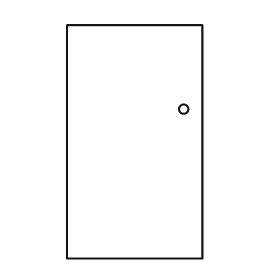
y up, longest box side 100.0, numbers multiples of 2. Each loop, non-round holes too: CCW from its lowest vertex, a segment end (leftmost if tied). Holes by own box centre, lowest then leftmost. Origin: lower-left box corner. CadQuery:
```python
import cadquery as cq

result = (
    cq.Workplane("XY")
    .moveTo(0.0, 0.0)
    .lineTo(58.0, 0.0)
    .lineTo(58.0, 100.0)
    .lineTo(0.0, 100.0)
    .close()
    .moveTo(50.0, 64.0)
    .circle(2.0)
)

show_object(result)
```